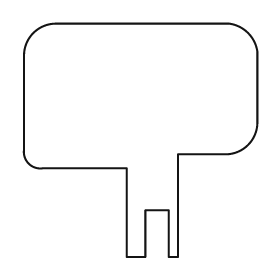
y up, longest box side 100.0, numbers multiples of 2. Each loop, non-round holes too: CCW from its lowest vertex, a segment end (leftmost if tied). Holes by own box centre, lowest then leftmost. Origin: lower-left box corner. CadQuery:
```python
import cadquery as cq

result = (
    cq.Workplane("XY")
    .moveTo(44.0, 0.0)
    .lineTo(52.0, 0.0)
    .lineTo(52.0, 20.0)
    .lineTo(62.0, 20.0)
    .lineTo(62.0, 0.0)
    .lineTo(66.0, 0.0)
    .lineTo(66.0, 44.0)
    .lineTo(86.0, 44.0)
    .threePointArc((96.0, 48.0), (100.0, 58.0))
    .lineTo(100.0, 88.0)
    .threePointArc((96.0, 96.0), (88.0, 100.0))
    .lineTo(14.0, 100.0)
    .threePointArc((4.0, 96.0), (0.0, 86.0))
    .lineTo(0.0, 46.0)
    .threePointArc((2.0, 40.0), (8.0, 38.0))
    .lineTo(44.0, 38.0)
    .close()
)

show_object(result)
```